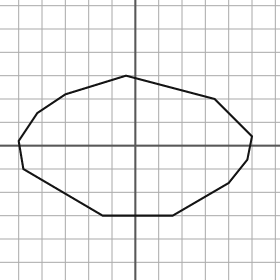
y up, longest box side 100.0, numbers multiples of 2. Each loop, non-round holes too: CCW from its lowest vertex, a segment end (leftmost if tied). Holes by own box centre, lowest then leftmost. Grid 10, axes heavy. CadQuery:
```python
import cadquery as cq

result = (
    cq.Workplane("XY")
    .moveTo(-14.0, -30.0)
    .lineTo(16.0, -30.0)
    .lineTo(40.0, -16.0)
    .lineTo(48.0, -6.0)
    .lineTo(50.0, 4.0)
    .lineTo(34.0, 20.0)
    .lineTo(-4.0, 30.0)
    .lineTo(-30.0, 22.0)
    .lineTo(-42.0, 14.0)
    .lineTo(-50.0, 2.0)
    .lineTo(-48.0, -10.0)
    .close()
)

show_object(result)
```